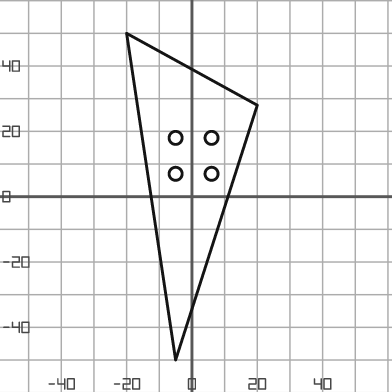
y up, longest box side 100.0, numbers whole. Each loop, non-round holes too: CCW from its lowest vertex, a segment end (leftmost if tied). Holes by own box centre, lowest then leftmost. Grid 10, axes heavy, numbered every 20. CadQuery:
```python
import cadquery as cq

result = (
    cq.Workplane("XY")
    .moveTo(-5.0, -50.0)
    .lineTo(20.0, 28.0)
    .lineTo(-20.0, 50.0)
    .close()
    .moveTo(-5.0, 7.0)
    .circle(2.0)
    .moveTo(6.0, 7.0)
    .circle(2.0)
    .moveTo(-5.0, 18.0)
    .circle(2.0)
    .moveTo(6.0, 18.0)
    .circle(2.0)
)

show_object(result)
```